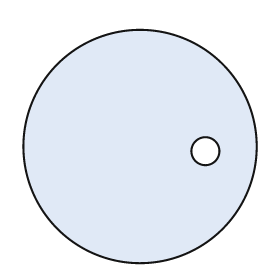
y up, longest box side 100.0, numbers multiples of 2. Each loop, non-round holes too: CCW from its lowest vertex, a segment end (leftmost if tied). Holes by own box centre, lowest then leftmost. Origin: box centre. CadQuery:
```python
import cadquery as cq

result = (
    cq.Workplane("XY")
    .moveTo(0.0, 0.0)
    .circle(50.0)
    .moveTo(28.0, -2.0)
    .circle(6.0)
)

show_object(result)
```